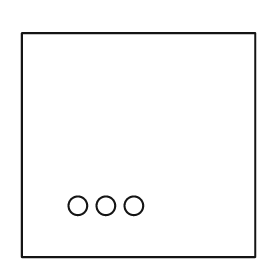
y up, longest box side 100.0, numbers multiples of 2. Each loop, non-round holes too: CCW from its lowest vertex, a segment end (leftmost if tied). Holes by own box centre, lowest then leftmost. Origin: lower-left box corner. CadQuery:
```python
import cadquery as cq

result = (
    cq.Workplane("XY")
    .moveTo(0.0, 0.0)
    .lineTo(100.0, 0.0)
    .lineTo(100.0, 96.0)
    .lineTo(0.0, 96.0)
    .close()
    .moveTo(24.0, 22.0)
    .circle(4.0)
    .moveTo(36.0, 22.0)
    .circle(4.0)
    .moveTo(48.0, 22.0)
    .circle(4.0)
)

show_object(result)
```